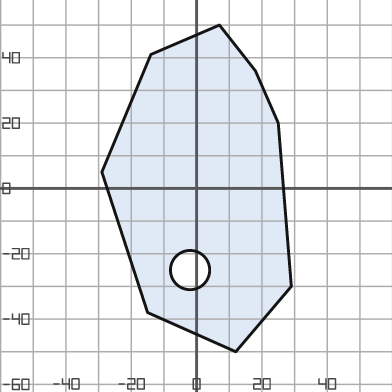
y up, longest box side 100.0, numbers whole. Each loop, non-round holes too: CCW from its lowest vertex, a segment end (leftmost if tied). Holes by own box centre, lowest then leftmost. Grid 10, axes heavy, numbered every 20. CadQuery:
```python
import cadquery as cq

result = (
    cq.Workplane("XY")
    .moveTo(12.0, -50.0)
    .lineTo(29.0, -30.0)
    .lineTo(25.0, 20.0)
    .lineTo(18.0, 36.0)
    .lineTo(7.0, 50.0)
    .lineTo(-14.0, 41.0)
    .lineTo(-29.0, 5.0)
    .lineTo(-15.0, -38.0)
    .close()
    .moveTo(-2.0, -25.0)
    .circle(6.0)
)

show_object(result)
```